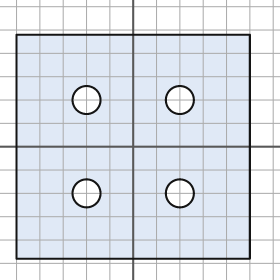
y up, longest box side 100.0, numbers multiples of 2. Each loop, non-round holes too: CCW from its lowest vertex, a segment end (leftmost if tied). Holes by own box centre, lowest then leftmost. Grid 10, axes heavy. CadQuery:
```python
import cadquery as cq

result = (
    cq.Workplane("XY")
    .moveTo(-50.0, -48.0)
    .lineTo(50.0, -48.0)
    .lineTo(50.0, 48.0)
    .lineTo(-50.0, 48.0)
    .close()
    .moveTo(-20.0, -20.0)
    .circle(6.0)
    .moveTo(20.0, -20.0)
    .circle(6.0)
    .moveTo(-20.0, 20.0)
    .circle(6.0)
    .moveTo(20.0, 20.0)
    .circle(6.0)
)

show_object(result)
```